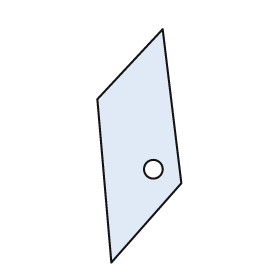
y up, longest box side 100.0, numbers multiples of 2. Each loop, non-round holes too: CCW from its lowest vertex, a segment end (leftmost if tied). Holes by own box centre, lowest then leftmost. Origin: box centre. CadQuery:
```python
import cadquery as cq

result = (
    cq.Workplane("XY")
    .moveTo(-12.0, -50.0)
    .lineTo(18.0, -16.0)
    .lineTo(10.0, 50.0)
    .lineTo(-18.0, 20.0)
    .close()
    .moveTo(6.0, -10.0)
    .circle(4.0)
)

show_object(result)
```